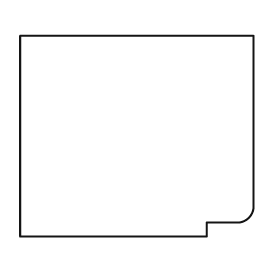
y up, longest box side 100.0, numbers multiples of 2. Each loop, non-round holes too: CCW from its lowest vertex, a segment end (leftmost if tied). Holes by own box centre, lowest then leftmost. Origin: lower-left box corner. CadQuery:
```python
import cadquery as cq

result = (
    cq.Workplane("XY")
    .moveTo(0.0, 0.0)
    .lineTo(80.0, 0.0)
    .lineTo(80.0, 6.0)
    .lineTo(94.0, 6.0)
    .threePointArc((98.0, 8.0), (100.0, 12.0))
    .lineTo(100.0, 86.0)
    .lineTo(0.0, 86.0)
    .close()
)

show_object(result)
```